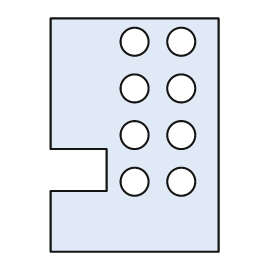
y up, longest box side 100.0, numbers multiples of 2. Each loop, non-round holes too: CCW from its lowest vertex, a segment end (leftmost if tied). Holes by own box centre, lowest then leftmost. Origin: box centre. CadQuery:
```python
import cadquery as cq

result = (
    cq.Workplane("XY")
    .moveTo(-36.0, -50.0)
    .lineTo(36.0, -50.0)
    .lineTo(36.0, 50.0)
    .lineTo(-36.0, 50.0)
    .lineTo(-36.0, -6.0)
    .lineTo(-12.0, -6.0)
    .lineTo(-12.0, -24.0)
    .lineTo(-36.0, -24.0)
    .close()
    .moveTo(0.0, -20.0)
    .circle(6.0)
    .moveTo(20.0, -20.0)
    .circle(6.0)
    .moveTo(0.0, 0.0)
    .circle(6.0)
    .moveTo(20.0, 0.0)
    .circle(6.0)
    .moveTo(0.0, 20.0)
    .circle(6.0)
    .moveTo(20.0, 20.0)
    .circle(6.0)
    .moveTo(0.0, 40.0)
    .circle(6.0)
    .moveTo(20.0, 40.0)
    .circle(6.0)
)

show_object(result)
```